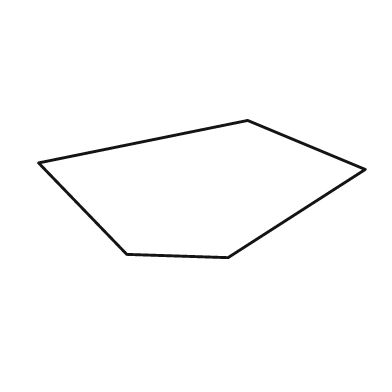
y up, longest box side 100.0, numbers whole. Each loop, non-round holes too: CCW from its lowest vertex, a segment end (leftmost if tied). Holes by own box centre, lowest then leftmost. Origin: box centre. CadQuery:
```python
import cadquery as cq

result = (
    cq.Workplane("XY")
    .moveTo(8.0, -21.0)
    .lineTo(50.0, 6.0)
    .lineTo(14.0, 21.0)
    .lineTo(-50.0, 8.0)
    .lineTo(-23.0, -20.0)
    .close()
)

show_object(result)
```